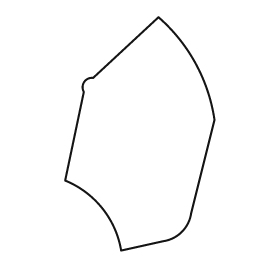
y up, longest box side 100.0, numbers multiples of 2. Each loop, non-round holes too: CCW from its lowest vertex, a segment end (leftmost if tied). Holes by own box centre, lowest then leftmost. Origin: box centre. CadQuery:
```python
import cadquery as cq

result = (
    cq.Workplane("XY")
    .moveTo(-8.0, -50.0)
    .lineTo(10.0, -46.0)
    .threePointArc((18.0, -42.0), (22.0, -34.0))
    .lineTo(32.0, 6.0)
    .threePointArc((24.0, 30.0), (8.0, 50.0))
    .lineTo(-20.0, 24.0)
    .threePointArc((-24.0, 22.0), (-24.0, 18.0))
    .lineTo(-32.0, -20.0)
    .threePointArc((-16.0, -32.0), (-8.0, -50.0))
    .close()
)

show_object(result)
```